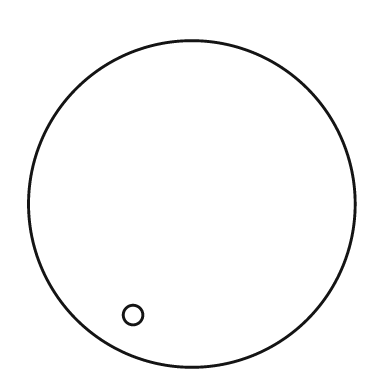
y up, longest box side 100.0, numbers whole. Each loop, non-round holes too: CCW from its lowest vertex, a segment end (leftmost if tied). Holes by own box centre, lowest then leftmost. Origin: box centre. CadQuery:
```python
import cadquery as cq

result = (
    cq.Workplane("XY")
    .moveTo(0.0, 0.0)
    .circle(50.0)
    .moveTo(-18.0, -34.0)
    .circle(3.0)
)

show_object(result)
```